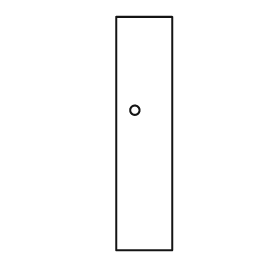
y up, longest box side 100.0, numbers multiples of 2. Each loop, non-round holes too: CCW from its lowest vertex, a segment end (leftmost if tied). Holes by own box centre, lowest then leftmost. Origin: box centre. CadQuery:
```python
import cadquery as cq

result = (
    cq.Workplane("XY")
    .moveTo(-12.0, -50.0)
    .lineTo(12.0, -50.0)
    .lineTo(12.0, 50.0)
    .lineTo(-12.0, 50.0)
    .close()
    .moveTo(-4.0, 10.0)
    .circle(2.0)
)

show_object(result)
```